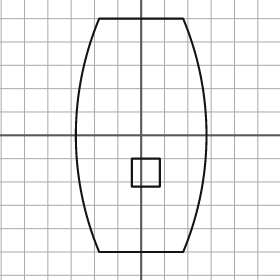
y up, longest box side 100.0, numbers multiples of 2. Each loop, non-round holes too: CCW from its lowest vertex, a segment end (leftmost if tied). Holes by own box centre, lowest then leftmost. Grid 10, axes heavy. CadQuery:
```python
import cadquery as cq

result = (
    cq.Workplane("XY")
    .moveTo(-18.0, -50.0)
    .lineTo(18.0, -50.0)
    .threePointArc((28.0, 0.0), (18.0, 50.0))
    .lineTo(-18.0, 50.0)
    .threePointArc((-28.0, 0.0), (-18.0, -50.0))
    .close()
    .moveTo(-4.0, -22.0)
    .lineTo(8.0, -22.0)
    .lineTo(8.0, -10.0)
    .lineTo(-4.0, -10.0)
    .close()
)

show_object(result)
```